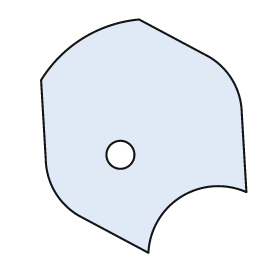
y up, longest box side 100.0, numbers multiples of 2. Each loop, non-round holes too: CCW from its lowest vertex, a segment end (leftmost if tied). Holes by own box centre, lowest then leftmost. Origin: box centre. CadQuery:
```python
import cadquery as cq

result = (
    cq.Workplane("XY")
    .moveTo(2.0, -50.0)
    .threePointArc((16.0, -26.0), (44.0, -24.0))
    .lineTo(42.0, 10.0)
    .threePointArc((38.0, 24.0), (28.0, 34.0))
    .lineTo(-2.0, 50.0)
    .threePointArc((-26.0, 42.0), (-44.0, 24.0))
    .lineTo(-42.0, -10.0)
    .threePointArc((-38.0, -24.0), (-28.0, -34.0))
    .close()
    .moveTo(-10.0, -8.0)
    .circle(6.0)
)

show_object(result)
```